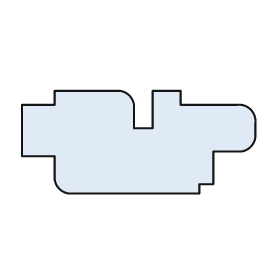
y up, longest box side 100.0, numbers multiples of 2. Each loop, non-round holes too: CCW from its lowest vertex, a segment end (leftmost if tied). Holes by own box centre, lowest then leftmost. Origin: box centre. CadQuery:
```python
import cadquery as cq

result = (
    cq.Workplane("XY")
    .moveTo(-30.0, -22.0)
    .lineTo(26.0, -22.0)
    .lineTo(26.0, -18.0)
    .lineTo(32.0, -18.0)
    .lineTo(32.0, -4.0)
    .lineTo(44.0, -4.0)
    .threePointArc((48.0, -2.0), (50.0, 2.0))
    .lineTo(50.0, 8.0)
    .threePointArc((48.0, 14.0), (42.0, 16.0))
    .lineTo(18.0, 16.0)
    .lineTo(18.0, 22.0)
    .lineTo(6.0, 22.0)
    .lineTo(6.0, 6.0)
    .lineTo(-2.0, 6.0)
    .lineTo(-2.0, 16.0)
    .threePointArc((-4.0, 20.0), (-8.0, 22.0))
    .lineTo(-36.0, 22.0)
    .lineTo(-36.0, 16.0)
    .lineTo(-50.0, 16.0)
    .lineTo(-50.0, -6.0)
    .lineTo(-36.0, -6.0)
    .lineTo(-36.0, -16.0)
    .threePointArc((-34.0, -20.0), (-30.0, -22.0))
    .close()
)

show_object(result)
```